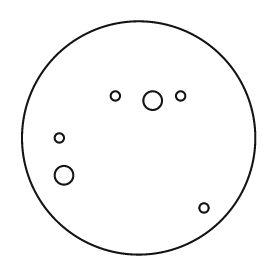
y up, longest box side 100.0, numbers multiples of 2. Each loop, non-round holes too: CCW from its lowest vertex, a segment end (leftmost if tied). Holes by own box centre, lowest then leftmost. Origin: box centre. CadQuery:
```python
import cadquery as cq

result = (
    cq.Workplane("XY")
    .moveTo(0.0, 0.0)
    .circle(50.0)
    .moveTo(28.0, -30.0)
    .circle(2.0)
    .moveTo(-32.0, -16.0)
    .circle(4.0)
    .moveTo(-34.0, 0.0)
    .circle(2.0)
    .moveTo(6.0, 16.0)
    .circle(4.0)
    .moveTo(-10.0, 18.0)
    .circle(2.0)
    .moveTo(18.0, 18.0)
    .circle(2.0)
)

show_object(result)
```